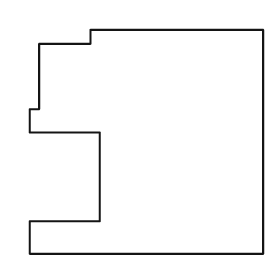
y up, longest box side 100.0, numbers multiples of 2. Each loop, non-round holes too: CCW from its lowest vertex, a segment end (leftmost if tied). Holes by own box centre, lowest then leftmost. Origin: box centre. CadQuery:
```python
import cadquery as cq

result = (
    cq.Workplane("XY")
    .moveTo(-50.0, -48.0)
    .lineTo(50.0, -48.0)
    .lineTo(50.0, 48.0)
    .lineTo(-24.0, 48.0)
    .lineTo(-24.0, 42.0)
    .lineTo(-46.0, 42.0)
    .lineTo(-46.0, 14.0)
    .lineTo(-50.0, 14.0)
    .lineTo(-50.0, 4.0)
    .lineTo(-20.0, 4.0)
    .lineTo(-20.0, -34.0)
    .lineTo(-50.0, -34.0)
    .close()
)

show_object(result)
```